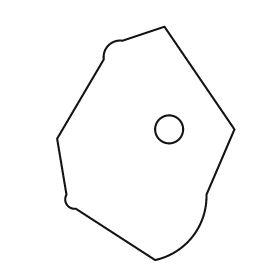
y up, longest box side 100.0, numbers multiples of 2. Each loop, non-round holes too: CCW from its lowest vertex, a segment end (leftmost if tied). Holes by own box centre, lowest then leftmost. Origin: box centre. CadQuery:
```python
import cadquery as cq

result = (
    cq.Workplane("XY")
    .moveTo(4.0, -50.0)
    .threePointArc((20.0, -40.0), (26.0, -22.0))
    .lineTo(38.0, 6.0)
    .lineTo(8.0, 50.0)
    .lineTo(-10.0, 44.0)
    .threePointArc((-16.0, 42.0), (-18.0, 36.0))
    .lineTo(-38.0, 2.0)
    .lineTo(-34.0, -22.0)
    .threePointArc((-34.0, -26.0), (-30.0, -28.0))
    .close()
    .moveTo(10.0, 6.0)
    .circle(6.0)
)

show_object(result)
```